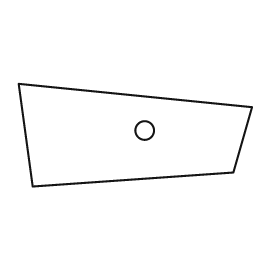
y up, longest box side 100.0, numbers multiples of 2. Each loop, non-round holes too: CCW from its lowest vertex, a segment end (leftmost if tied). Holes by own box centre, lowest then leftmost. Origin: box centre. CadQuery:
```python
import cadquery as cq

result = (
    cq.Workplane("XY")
    .moveTo(-44.0, -22.0)
    .lineTo(42.0, -16.0)
    .lineTo(50.0, 12.0)
    .lineTo(-50.0, 22.0)
    .close()
    .moveTo(4.0, 2.0)
    .circle(4.0)
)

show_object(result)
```